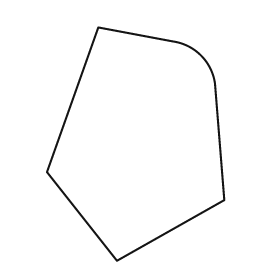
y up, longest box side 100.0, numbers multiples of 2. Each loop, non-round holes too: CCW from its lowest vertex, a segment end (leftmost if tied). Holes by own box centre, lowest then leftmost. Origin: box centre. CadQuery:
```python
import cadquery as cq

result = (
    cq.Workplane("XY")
    .moveTo(-8.0, -50.0)
    .lineTo(38.0, -24.0)
    .lineTo(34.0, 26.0)
    .threePointArc((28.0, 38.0), (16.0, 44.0))
    .lineTo(-16.0, 50.0)
    .lineTo(-38.0, -12.0)
    .close()
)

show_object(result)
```